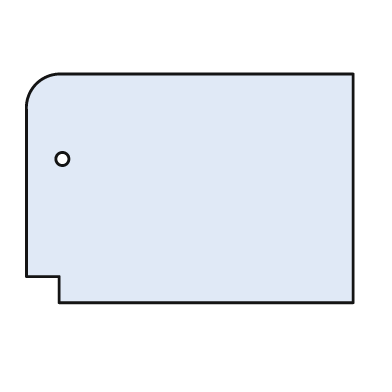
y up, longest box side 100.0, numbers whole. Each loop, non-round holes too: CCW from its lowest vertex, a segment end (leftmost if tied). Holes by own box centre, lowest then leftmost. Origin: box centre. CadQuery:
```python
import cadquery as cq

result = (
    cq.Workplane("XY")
    .moveTo(-40.0, -35.0)
    .lineTo(50.0, -35.0)
    .lineTo(50.0, 35.0)
    .lineTo(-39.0, 35.0)
    .threePointArc((-47.0, 32.0), (-50.0, 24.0))
    .lineTo(-50.0, -27.0)
    .lineTo(-40.0, -27.0)
    .close()
    .moveTo(-39.0, 9.0)
    .circle(2.0)
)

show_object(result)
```